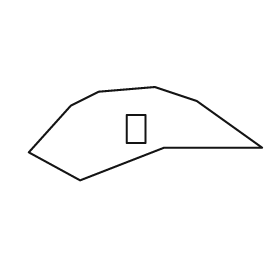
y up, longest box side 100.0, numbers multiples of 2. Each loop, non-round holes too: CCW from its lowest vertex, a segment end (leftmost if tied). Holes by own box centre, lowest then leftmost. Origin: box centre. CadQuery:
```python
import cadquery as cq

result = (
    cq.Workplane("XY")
    .moveTo(-28.0, -20.0)
    .lineTo(8.0, -6.0)
    .lineTo(50.0, -6.0)
    .lineTo(22.0, 14.0)
    .lineTo(4.0, 20.0)
    .lineTo(-20.0, 18.0)
    .lineTo(-32.0, 12.0)
    .lineTo(-50.0, -8.0)
    .close()
    .moveTo(-8.0, -4.0)
    .lineTo(0.0, -4.0)
    .lineTo(0.0, 8.0)
    .lineTo(-8.0, 8.0)
    .close()
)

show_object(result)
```